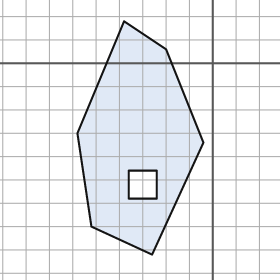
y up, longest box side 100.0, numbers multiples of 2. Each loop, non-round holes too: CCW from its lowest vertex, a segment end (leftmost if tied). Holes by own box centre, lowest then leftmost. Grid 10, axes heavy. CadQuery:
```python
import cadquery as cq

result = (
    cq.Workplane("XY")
    .moveTo(-26.0, -82.0)
    .lineTo(-4.0, -34.0)
    .lineTo(-20.0, 6.0)
    .lineTo(-38.0, 18.0)
    .lineTo(-58.0, -30.0)
    .lineTo(-52.0, -70.0)
    .close()
    .moveTo(-36.0, -58.0)
    .lineTo(-24.0, -58.0)
    .lineTo(-24.0, -46.0)
    .lineTo(-36.0, -46.0)
    .close()
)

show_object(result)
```